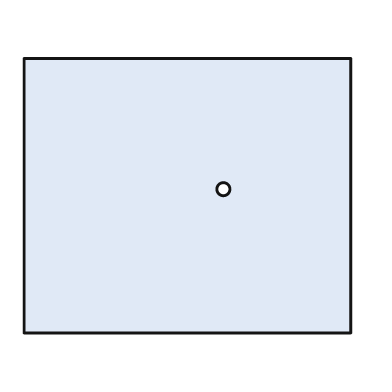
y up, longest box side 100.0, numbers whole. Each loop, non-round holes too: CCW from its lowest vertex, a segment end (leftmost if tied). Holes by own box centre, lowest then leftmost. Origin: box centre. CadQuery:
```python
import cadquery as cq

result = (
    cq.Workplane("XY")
    .moveTo(-50.0, -42.0)
    .lineTo(50.0, -42.0)
    .lineTo(50.0, 42.0)
    .lineTo(-50.0, 42.0)
    .close()
    .moveTo(11.0, 2.0)
    .circle(2.0)
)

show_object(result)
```